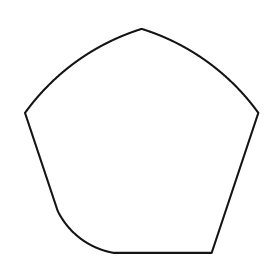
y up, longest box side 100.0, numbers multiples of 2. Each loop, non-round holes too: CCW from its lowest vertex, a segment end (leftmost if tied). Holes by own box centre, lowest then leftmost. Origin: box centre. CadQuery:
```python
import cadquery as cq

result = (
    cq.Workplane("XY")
    .moveTo(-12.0, -48.0)
    .lineTo(30.0, -48.0)
    .lineTo(50.0, 12.0)
    .threePointArc((28.0, 34.0), (0.0, 48.0))
    .threePointArc((-28.0, 34.0), (-50.0, 12.0))
    .lineTo(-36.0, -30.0)
    .threePointArc((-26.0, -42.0), (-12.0, -48.0))
    .close()
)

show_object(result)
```